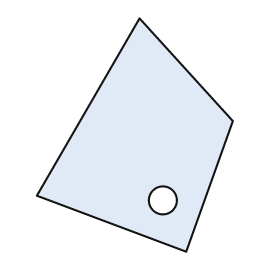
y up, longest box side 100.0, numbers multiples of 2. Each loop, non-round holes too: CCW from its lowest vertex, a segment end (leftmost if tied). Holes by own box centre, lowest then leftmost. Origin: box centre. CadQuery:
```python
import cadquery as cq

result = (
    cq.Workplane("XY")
    .moveTo(22.0, -50.0)
    .lineTo(42.0, 6.0)
    .lineTo(2.0, 50.0)
    .lineTo(-42.0, -26.0)
    .close()
    .moveTo(12.0, -28.0)
    .circle(6.0)
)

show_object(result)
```